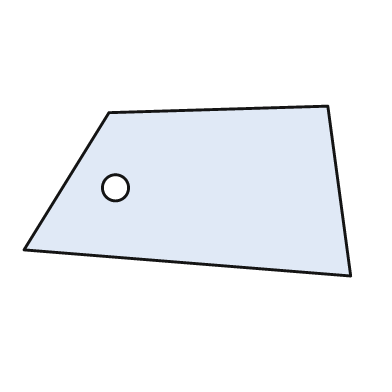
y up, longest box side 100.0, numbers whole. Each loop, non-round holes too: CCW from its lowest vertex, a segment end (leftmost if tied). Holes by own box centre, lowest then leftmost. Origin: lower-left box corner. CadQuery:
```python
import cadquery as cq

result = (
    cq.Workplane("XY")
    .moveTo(100.0, 0.0)
    .lineTo(93.0, 52.0)
    .lineTo(26.0, 50.0)
    .lineTo(0.0, 8.0)
    .close()
    .moveTo(28.0, 27.0)
    .circle(4.0)
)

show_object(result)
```